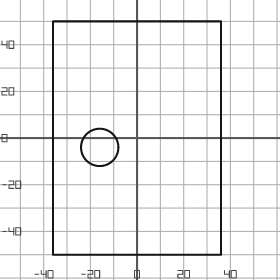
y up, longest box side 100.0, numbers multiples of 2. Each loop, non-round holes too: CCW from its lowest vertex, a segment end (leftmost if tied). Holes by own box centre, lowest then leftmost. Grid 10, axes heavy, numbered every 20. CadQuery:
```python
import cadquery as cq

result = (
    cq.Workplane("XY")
    .moveTo(-36.0, -50.0)
    .lineTo(36.0, -50.0)
    .lineTo(36.0, 50.0)
    .lineTo(-36.0, 50.0)
    .close()
    .moveTo(-16.0, -4.0)
    .circle(8.0)
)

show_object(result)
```